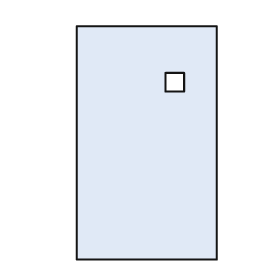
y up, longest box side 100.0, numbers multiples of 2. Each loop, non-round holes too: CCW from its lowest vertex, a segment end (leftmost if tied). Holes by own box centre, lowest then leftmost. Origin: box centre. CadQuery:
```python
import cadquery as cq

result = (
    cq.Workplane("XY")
    .moveTo(-30.0, -50.0)
    .lineTo(30.0, -50.0)
    .lineTo(30.0, 50.0)
    .lineTo(-30.0, 50.0)
    .close()
    .moveTo(8.0, 22.0)
    .lineTo(16.0, 22.0)
    .lineTo(16.0, 30.0)
    .lineTo(8.0, 30.0)
    .close()
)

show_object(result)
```